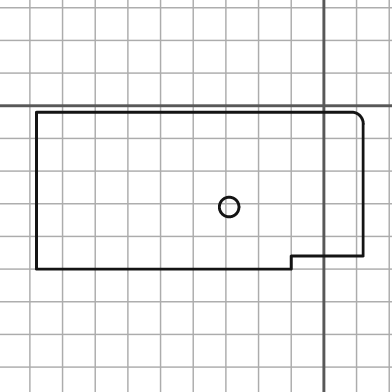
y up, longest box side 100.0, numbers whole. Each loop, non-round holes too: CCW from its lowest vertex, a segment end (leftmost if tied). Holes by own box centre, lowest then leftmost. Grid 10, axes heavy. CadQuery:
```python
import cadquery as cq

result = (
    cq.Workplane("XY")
    .moveTo(-88.0, -50.0)
    .lineTo(-10.0, -50.0)
    .lineTo(-10.0, -46.0)
    .lineTo(12.0, -46.0)
    .lineTo(12.0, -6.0)
    .threePointArc((11.0, -3.0), (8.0, -2.0))
    .lineTo(-88.0, -2.0)
    .close()
    .moveTo(-29.0, -31.0)
    .circle(3.0)
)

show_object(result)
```